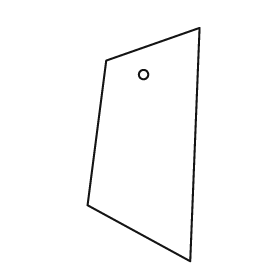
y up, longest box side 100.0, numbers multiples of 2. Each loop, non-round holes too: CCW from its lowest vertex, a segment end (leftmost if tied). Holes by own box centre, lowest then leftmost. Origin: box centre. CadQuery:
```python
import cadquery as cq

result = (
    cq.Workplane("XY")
    .moveTo(20.0, -50.0)
    .lineTo(24.0, 50.0)
    .lineTo(-16.0, 36.0)
    .lineTo(-24.0, -26.0)
    .close()
    .moveTo(0.0, 30.0)
    .circle(2.0)
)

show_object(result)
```